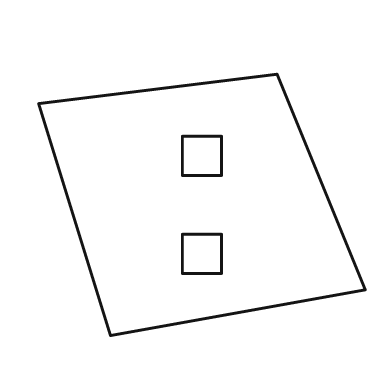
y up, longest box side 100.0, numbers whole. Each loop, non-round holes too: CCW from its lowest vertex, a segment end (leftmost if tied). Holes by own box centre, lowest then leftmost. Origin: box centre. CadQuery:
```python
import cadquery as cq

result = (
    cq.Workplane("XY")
    .moveTo(-28.0, -40.0)
    .lineTo(50.0, -26.0)
    .lineTo(23.0, 40.0)
    .lineTo(-50.0, 31.0)
    .close()
    .moveTo(-6.0, -21.0)
    .lineTo(6.0, -21.0)
    .lineTo(6.0, -9.0)
    .lineTo(-6.0, -9.0)
    .close()
    .moveTo(-6.0, 9.0)
    .lineTo(6.0, 9.0)
    .lineTo(6.0, 21.0)
    .lineTo(-6.0, 21.0)
    .close()
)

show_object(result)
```